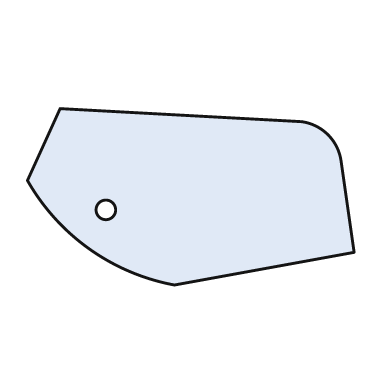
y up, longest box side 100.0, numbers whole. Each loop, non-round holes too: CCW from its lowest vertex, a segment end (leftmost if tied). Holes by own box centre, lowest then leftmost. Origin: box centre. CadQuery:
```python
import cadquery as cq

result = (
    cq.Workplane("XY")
    .moveTo(-5.0, -27.0)
    .lineTo(50.0, -17.0)
    .lineTo(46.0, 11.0)
    .threePointArc((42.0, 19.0), (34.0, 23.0))
    .lineTo(-40.0, 27.0)
    .lineTo(-50.0, 5.0)
    .threePointArc((-31.0, -16.0), (-5.0, -27.0))
    .close()
    .moveTo(-26.0, -4.0)
    .circle(3.0)
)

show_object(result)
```